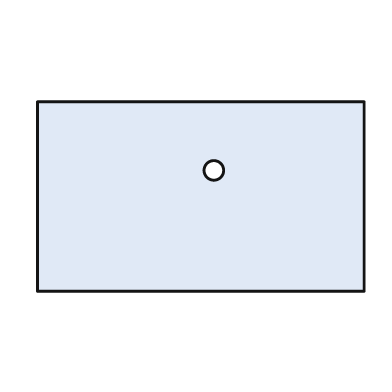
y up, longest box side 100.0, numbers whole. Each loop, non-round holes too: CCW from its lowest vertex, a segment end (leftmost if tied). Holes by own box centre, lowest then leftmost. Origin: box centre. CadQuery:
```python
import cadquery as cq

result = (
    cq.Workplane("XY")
    .moveTo(-50.0, -29.0)
    .lineTo(50.0, -29.0)
    .lineTo(50.0, 29.0)
    .lineTo(-50.0, 29.0)
    .close()
    .moveTo(4.0, 8.0)
    .circle(3.0)
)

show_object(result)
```